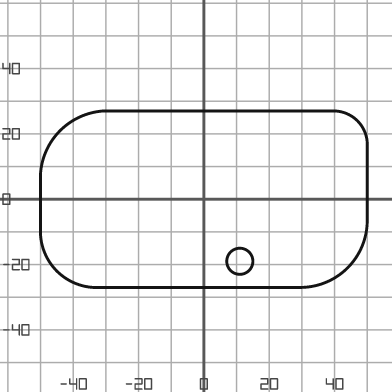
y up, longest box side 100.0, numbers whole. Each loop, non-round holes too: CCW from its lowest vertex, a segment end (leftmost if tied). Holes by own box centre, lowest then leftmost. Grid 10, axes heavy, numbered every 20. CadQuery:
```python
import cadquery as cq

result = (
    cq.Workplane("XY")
    .moveTo(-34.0, -27.0)
    .lineTo(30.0, -27.0)
    .threePointArc((44.0, -21.0), (50.0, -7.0))
    .lineTo(50.0, 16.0)
    .threePointArc((47.0, 24.0), (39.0, 27.0))
    .lineTo(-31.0, 27.0)
    .threePointArc((-44.0, 21.0), (-50.0, 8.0))
    .lineTo(-50.0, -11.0)
    .threePointArc((-45.0, -22.0), (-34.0, -27.0))
    .close()
    .moveTo(11.0, -19.0)
    .circle(4.0)
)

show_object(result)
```